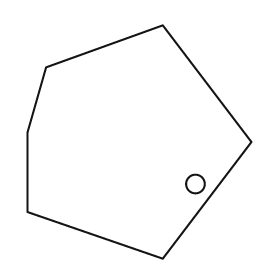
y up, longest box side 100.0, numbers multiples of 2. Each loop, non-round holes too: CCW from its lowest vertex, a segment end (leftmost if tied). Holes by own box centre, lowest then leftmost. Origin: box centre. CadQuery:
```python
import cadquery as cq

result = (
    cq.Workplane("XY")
    .moveTo(10.0, -50.0)
    .lineTo(48.0, 0.0)
    .lineTo(10.0, 50.0)
    .lineTo(-40.0, 32.0)
    .lineTo(-48.0, 4.0)
    .lineTo(-48.0, -30.0)
    .close()
    .moveTo(24.0, -18.0)
    .circle(4.0)
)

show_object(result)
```